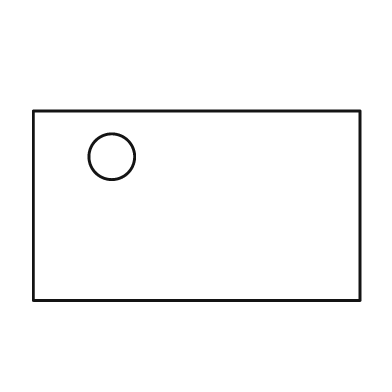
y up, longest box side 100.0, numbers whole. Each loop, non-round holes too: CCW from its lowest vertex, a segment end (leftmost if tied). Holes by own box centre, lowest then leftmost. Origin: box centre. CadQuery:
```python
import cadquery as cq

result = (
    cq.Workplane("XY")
    .moveTo(-50.0, -29.0)
    .lineTo(50.0, -29.0)
    .lineTo(50.0, 29.0)
    .lineTo(-50.0, 29.0)
    .close()
    .moveTo(-26.0, 15.0)
    .circle(7.0)
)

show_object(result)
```